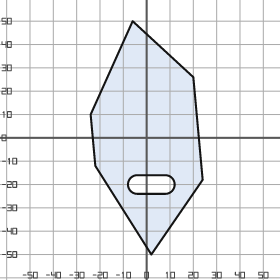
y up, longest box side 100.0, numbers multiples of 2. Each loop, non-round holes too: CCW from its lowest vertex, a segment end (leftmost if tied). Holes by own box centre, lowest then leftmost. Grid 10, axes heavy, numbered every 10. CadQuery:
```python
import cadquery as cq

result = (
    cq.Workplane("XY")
    .moveTo(2.0, -50.0)
    .lineTo(24.0, -18.0)
    .lineTo(20.0, 26.0)
    .lineTo(-6.0, 50.0)
    .lineTo(-24.0, 10.0)
    .lineTo(-22.0, -12.0)
    .close()
    .moveTo(-4.0, -24.0)
    .lineTo(8.0, -24.0)
    .threePointArc((12.0, -20.0), (8.0, -16.0))
    .lineTo(-4.0, -16.0)
    .threePointArc((-8.0, -20.0), (-4.0, -24.0))
    .close()
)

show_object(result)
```